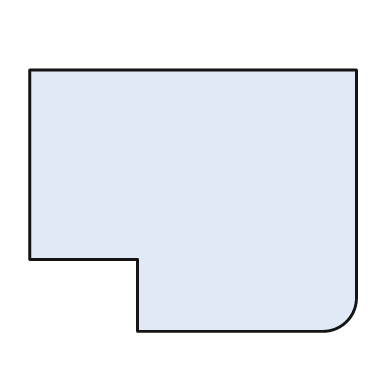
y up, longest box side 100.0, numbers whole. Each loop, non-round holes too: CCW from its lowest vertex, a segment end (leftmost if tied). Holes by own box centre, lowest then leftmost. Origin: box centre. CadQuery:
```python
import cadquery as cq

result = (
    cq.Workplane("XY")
    .moveTo(-17.0, -40.0)
    .lineTo(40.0, -40.0)
    .threePointArc((47.0, -37.0), (50.0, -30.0))
    .lineTo(50.0, 40.0)
    .lineTo(-50.0, 40.0)
    .lineTo(-50.0, -18.0)
    .lineTo(-17.0, -18.0)
    .close()
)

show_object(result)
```